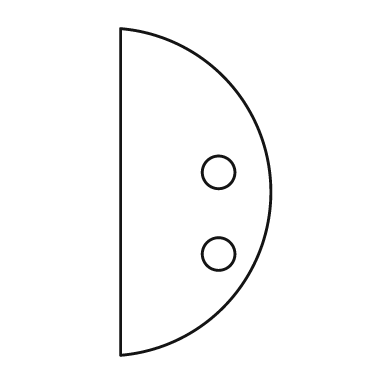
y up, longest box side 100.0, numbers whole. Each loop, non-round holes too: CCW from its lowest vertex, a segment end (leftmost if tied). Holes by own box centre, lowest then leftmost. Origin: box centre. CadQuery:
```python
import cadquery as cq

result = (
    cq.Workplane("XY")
    .moveTo(-23.0, -50.0)
    .threePointArc((23.0, 0.0), (-23.0, 50.0))
    .close()
    .moveTo(7.0, -19.0)
    .circle(5.0)
    .moveTo(7.0, 6.0)
    .circle(5.0)
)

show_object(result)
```